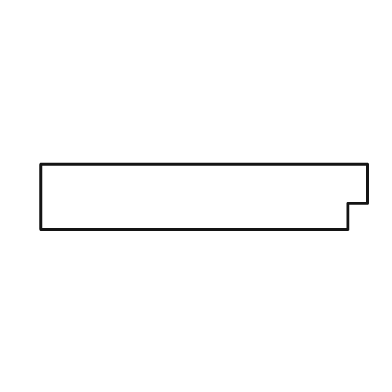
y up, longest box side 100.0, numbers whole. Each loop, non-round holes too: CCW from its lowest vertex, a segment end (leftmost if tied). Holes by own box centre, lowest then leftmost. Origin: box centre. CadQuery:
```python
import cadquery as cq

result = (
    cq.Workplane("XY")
    .moveTo(-50.0, -10.0)
    .lineTo(44.0, -10.0)
    .lineTo(44.0, -2.0)
    .lineTo(50.0, -2.0)
    .lineTo(50.0, 10.0)
    .lineTo(-50.0, 10.0)
    .close()
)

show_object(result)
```